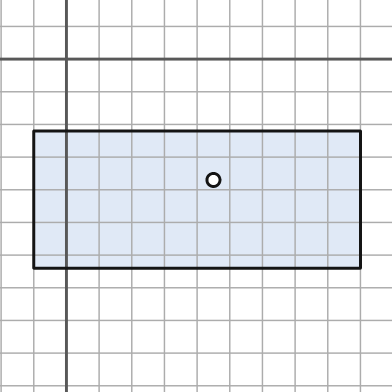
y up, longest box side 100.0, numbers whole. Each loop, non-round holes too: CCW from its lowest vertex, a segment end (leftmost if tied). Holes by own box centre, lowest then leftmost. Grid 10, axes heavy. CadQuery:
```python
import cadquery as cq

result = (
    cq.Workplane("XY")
    .moveTo(-10.0, -64.0)
    .lineTo(90.0, -64.0)
    .lineTo(90.0, -22.0)
    .lineTo(-10.0, -22.0)
    .close()
    .moveTo(45.0, -37.0)
    .circle(2.0)
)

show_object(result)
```